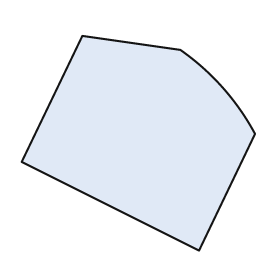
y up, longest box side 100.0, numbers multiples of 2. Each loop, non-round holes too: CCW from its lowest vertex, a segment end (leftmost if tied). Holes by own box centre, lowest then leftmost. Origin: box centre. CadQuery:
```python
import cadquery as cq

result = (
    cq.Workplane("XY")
    .moveTo(26.0, -46.0)
    .lineTo(50.0, 4.0)
    .threePointArc((36.0, 24.0), (18.0, 40.0))
    .lineTo(-24.0, 46.0)
    .lineTo(-50.0, -8.0)
    .close()
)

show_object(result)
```